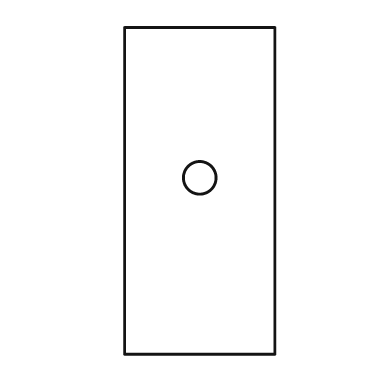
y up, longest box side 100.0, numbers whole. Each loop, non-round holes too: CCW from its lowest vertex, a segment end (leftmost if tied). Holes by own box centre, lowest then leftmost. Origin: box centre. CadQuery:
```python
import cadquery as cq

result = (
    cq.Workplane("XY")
    .moveTo(-23.0, -50.0)
    .lineTo(23.0, -50.0)
    .lineTo(23.0, 50.0)
    .lineTo(-23.0, 50.0)
    .close()
    .moveTo(0.0, 4.0)
    .circle(5.0)
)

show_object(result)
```